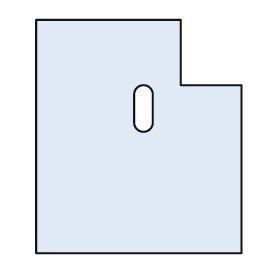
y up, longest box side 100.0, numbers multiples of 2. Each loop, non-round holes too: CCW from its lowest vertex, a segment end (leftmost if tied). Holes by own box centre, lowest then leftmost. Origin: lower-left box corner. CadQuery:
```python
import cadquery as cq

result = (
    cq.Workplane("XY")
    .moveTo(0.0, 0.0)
    .lineTo(88.0, 0.0)
    .lineTo(88.0, 72.0)
    .lineTo(62.0, 72.0)
    .lineTo(62.0, 100.0)
    .lineTo(0.0, 100.0)
    .close()
    .moveTo(42.0, 56.0)
    .threePointArc((46.0, 52.0), (50.0, 56.0))
    .lineTo(50.0, 68.0)
    .threePointArc((46.0, 72.0), (42.0, 68.0))
    .close()
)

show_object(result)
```